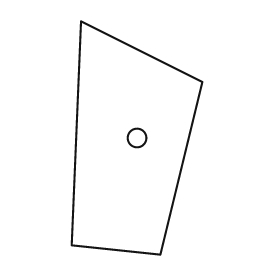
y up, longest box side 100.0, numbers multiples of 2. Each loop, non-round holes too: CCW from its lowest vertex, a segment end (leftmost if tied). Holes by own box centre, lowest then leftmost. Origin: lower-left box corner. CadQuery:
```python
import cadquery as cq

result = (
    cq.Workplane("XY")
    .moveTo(38.0, 0.0)
    .lineTo(56.0, 74.0)
    .lineTo(4.0, 100.0)
    .lineTo(0.0, 4.0)
    .close()
    .moveTo(28.0, 50.0)
    .circle(4.0)
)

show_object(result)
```